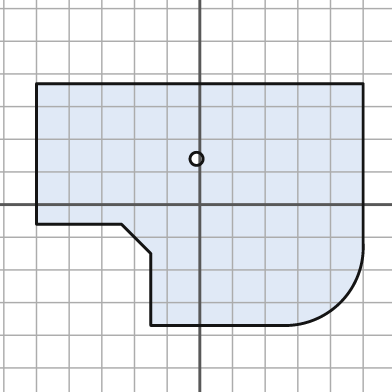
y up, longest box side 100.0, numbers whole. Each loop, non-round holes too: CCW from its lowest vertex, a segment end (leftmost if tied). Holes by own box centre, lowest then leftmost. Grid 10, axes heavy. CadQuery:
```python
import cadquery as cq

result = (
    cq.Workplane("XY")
    .moveTo(-15.0, -37.0)
    .lineTo(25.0, -37.0)
    .threePointArc((43.0, -30.0), (50.0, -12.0))
    .lineTo(50.0, 37.0)
    .lineTo(-50.0, 37.0)
    .lineTo(-50.0, -6.0)
    .lineTo(-24.0, -6.0)
    .lineTo(-15.0, -15.0)
    .close()
    .moveTo(-1.0, 14.0)
    .circle(2.0)
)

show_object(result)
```